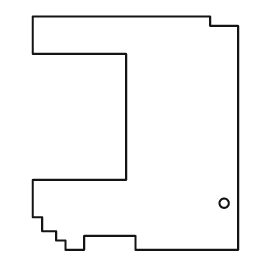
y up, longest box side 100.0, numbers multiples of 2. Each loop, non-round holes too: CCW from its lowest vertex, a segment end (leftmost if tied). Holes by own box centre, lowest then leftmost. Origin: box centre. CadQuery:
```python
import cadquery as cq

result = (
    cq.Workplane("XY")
    .moveTo(-30.0, -50.0)
    .lineTo(-22.0, -50.0)
    .lineTo(-22.0, -44.0)
    .lineTo(0.0, -44.0)
    .lineTo(0.0, -50.0)
    .lineTo(44.0, -50.0)
    .lineTo(44.0, 46.0)
    .lineTo(32.0, 46.0)
    .lineTo(32.0, 50.0)
    .lineTo(-44.0, 50.0)
    .lineTo(-44.0, 34.0)
    .lineTo(-4.0, 34.0)
    .lineTo(-4.0, -20.0)
    .lineTo(-44.0, -20.0)
    .lineTo(-44.0, -36.0)
    .lineTo(-40.0, -36.0)
    .lineTo(-40.0, -42.0)
    .lineTo(-34.0, -42.0)
    .lineTo(-34.0, -46.0)
    .lineTo(-30.0, -46.0)
    .close()
    .moveTo(38.0, -30.0)
    .circle(2.0)
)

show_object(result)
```